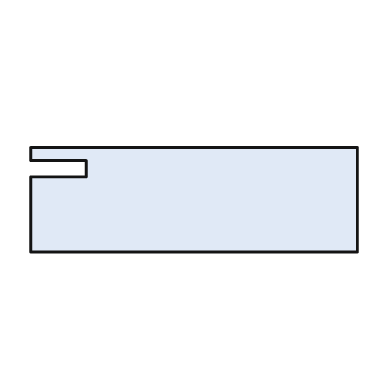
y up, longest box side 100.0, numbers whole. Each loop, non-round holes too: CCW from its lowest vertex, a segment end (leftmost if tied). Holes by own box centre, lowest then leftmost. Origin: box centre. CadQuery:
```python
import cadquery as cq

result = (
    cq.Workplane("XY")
    .moveTo(-50.0, -16.0)
    .lineTo(50.0, -16.0)
    .lineTo(50.0, 16.0)
    .lineTo(-50.0, 16.0)
    .lineTo(-50.0, 12.0)
    .lineTo(-33.0, 12.0)
    .lineTo(-33.0, 7.0)
    .lineTo(-50.0, 7.0)
    .close()
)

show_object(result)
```